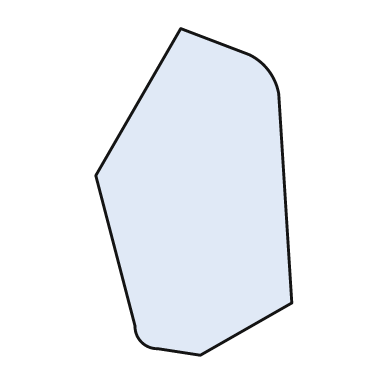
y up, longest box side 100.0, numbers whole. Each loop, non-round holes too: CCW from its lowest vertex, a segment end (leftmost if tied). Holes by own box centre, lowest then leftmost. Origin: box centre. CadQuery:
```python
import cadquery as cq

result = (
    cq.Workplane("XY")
    .moveTo(2.0, -50.0)
    .lineTo(30.0, -34.0)
    .lineTo(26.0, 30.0)
    .threePointArc((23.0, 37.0), (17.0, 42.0))
    .lineTo(-4.0, 50.0)
    .lineTo(-30.0, 5.0)
    .lineTo(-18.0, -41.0)
    .threePointArc((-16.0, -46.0), (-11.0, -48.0))
    .close()
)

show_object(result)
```